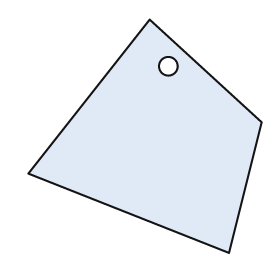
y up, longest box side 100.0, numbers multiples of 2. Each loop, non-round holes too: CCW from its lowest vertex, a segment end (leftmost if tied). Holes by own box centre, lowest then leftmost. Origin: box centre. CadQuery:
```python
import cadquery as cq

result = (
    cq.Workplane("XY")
    .moveTo(36.0, -50.0)
    .lineTo(50.0, 6.0)
    .lineTo(2.0, 50.0)
    .lineTo(-50.0, -16.0)
    .close()
    .moveTo(10.0, 30.0)
    .circle(4.0)
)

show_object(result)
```